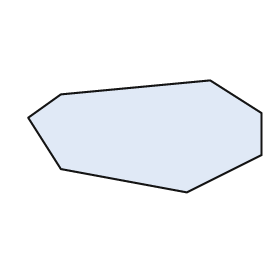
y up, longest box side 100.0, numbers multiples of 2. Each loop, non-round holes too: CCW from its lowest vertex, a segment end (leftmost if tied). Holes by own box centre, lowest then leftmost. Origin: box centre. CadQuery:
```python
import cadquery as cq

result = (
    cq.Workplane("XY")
    .moveTo(18.0, -24.0)
    .lineTo(50.0, -8.0)
    .lineTo(50.0, 10.0)
    .lineTo(28.0, 24.0)
    .lineTo(-36.0, 18.0)
    .lineTo(-50.0, 8.0)
    .lineTo(-36.0, -14.0)
    .close()
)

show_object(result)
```